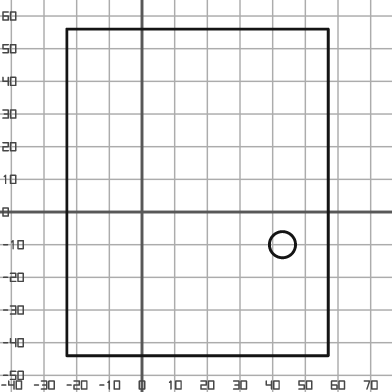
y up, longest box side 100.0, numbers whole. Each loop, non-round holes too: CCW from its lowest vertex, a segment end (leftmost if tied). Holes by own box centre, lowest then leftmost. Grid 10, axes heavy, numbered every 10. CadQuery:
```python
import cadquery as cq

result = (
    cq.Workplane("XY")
    .moveTo(-23.0, -44.0)
    .lineTo(57.0, -44.0)
    .lineTo(57.0, 56.0)
    .lineTo(-23.0, 56.0)
    .close()
    .moveTo(43.0, -10.0)
    .circle(4.0)
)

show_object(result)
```